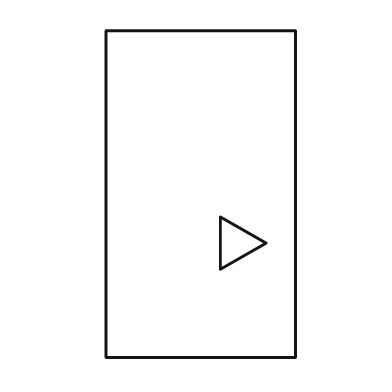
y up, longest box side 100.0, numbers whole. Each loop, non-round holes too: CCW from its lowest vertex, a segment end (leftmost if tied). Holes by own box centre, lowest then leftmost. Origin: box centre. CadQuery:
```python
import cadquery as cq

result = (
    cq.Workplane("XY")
    .moveTo(-29.0, -50.0)
    .lineTo(29.0, -50.0)
    .lineTo(29.0, 50.0)
    .lineTo(-29.0, 50.0)
    .close()
    .moveTo(6.0, -23.0)
    .lineTo(20.0, -15.0)
    .lineTo(6.0, -7.0)
    .close()
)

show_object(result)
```